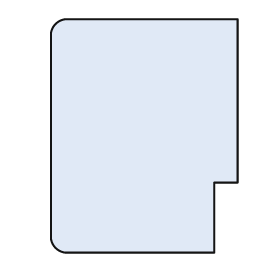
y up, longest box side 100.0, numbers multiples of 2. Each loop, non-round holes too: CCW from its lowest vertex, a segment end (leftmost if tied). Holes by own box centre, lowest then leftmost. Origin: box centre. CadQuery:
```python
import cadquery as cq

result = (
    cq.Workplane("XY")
    .moveTo(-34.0, -50.0)
    .lineTo(30.0, -50.0)
    .lineTo(30.0, -20.0)
    .lineTo(40.0, -20.0)
    .lineTo(40.0, 50.0)
    .lineTo(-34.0, 50.0)
    .threePointArc((-38.0, 48.0), (-40.0, 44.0))
    .lineTo(-40.0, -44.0)
    .threePointArc((-38.0, -48.0), (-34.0, -50.0))
    .close()
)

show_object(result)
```